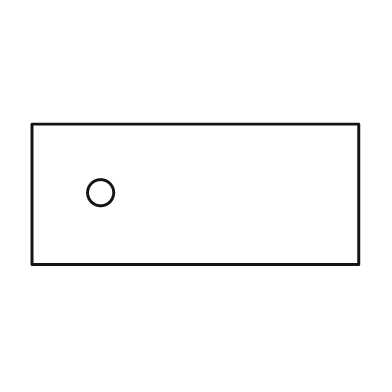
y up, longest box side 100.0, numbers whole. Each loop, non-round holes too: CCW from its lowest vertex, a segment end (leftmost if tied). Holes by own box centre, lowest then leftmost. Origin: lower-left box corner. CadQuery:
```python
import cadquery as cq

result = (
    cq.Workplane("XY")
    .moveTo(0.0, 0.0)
    .lineTo(100.0, 0.0)
    .lineTo(100.0, 43.0)
    .lineTo(0.0, 43.0)
    .close()
    .moveTo(21.0, 22.0)
    .circle(4.0)
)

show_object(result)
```